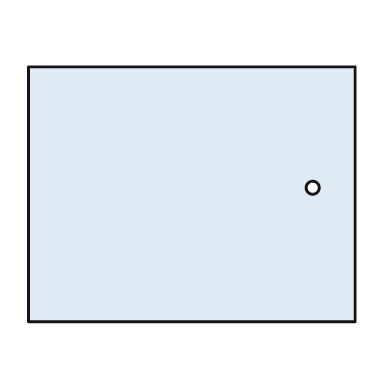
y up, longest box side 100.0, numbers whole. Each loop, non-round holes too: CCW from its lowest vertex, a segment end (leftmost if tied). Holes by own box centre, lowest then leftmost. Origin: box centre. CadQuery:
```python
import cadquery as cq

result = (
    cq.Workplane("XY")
    .moveTo(-50.0, -39.0)
    .lineTo(50.0, -39.0)
    .lineTo(50.0, 39.0)
    .lineTo(-50.0, 39.0)
    .close()
    .moveTo(37.0, 2.0)
    .circle(2.0)
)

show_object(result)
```